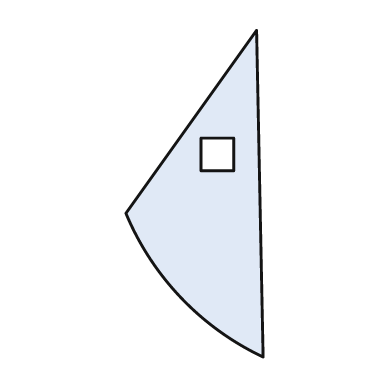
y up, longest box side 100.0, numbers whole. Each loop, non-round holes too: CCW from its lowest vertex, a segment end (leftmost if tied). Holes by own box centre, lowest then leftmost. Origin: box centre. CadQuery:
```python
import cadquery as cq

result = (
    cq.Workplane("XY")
    .moveTo(21.0, -50.0)
    .lineTo(19.0, 50.0)
    .lineTo(-21.0, -6.0)
    .threePointArc((-4.0, -32.0), (21.0, -50.0))
    .close()
    .moveTo(2.0, 7.0)
    .lineTo(12.0, 7.0)
    .lineTo(12.0, 17.0)
    .lineTo(2.0, 17.0)
    .close()
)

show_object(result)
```